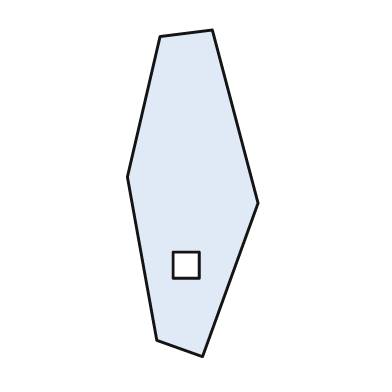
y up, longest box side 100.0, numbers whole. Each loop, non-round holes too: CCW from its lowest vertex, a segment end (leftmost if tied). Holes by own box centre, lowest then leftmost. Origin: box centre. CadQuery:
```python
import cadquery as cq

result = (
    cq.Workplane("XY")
    .moveTo(3.0, -50.0)
    .lineTo(20.0, -3.0)
    .lineTo(6.0, 50.0)
    .lineTo(-10.0, 48.0)
    .lineTo(-20.0, 5.0)
    .lineTo(-11.0, -45.0)
    .close()
    .moveTo(-6.0, -26.0)
    .lineTo(2.0, -26.0)
    .lineTo(2.0, -18.0)
    .lineTo(-6.0, -18.0)
    .close()
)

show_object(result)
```